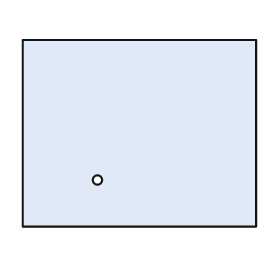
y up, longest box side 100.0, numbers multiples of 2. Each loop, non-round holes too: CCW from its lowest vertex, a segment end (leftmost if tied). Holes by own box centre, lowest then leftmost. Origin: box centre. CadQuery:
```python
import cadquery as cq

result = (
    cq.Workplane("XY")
    .moveTo(-50.0, -40.0)
    .lineTo(50.0, -40.0)
    .lineTo(50.0, 40.0)
    .lineTo(-50.0, 40.0)
    .close()
    .moveTo(-18.0, -20.0)
    .circle(2.0)
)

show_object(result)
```